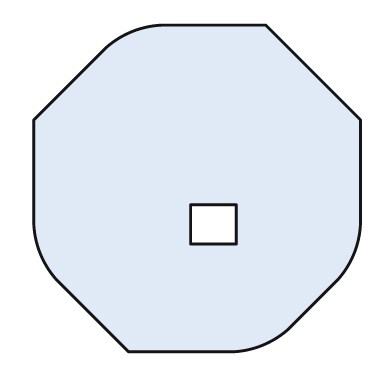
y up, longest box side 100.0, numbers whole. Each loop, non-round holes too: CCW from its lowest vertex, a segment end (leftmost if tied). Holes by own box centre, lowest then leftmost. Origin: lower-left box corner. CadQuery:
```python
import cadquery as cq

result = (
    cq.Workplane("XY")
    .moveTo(29.0, 0.0)
    .lineTo(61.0, 0.0)
    .threePointArc((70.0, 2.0), (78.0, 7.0))
    .lineTo(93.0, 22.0)
    .threePointArc((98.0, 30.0), (100.0, 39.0))
    .lineTo(100.0, 71.0)
    .lineTo(71.0, 100.0)
    .lineTo(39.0, 100.0)
    .threePointArc((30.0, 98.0), (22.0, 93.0))
    .lineTo(0.0, 71.0)
    .lineTo(0.0, 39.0)
    .threePointArc((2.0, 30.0), (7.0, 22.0))
    .close()
    .moveTo(48.0, 33.0)
    .lineTo(62.0, 33.0)
    .lineTo(62.0, 45.0)
    .lineTo(48.0, 45.0)
    .close()
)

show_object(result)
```